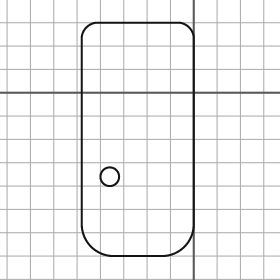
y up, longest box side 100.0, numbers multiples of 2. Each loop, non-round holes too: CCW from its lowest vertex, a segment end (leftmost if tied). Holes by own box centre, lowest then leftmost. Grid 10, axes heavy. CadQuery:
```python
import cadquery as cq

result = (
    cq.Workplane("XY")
    .moveTo(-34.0, -70.0)
    .lineTo(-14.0, -70.0)
    .threePointArc((-4.0, -66.0), (0.0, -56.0))
    .lineTo(0.0, 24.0)
    .threePointArc((-2.0, 28.0), (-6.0, 30.0))
    .lineTo(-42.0, 30.0)
    .threePointArc((-46.0, 28.0), (-48.0, 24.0))
    .lineTo(-48.0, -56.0)
    .threePointArc((-44.0, -66.0), (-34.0, -70.0))
    .close()
    .moveTo(-36.0, -36.0)
    .circle(4.0)
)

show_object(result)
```